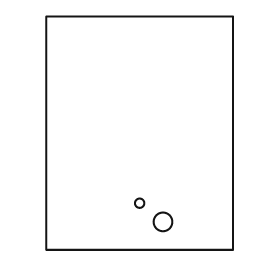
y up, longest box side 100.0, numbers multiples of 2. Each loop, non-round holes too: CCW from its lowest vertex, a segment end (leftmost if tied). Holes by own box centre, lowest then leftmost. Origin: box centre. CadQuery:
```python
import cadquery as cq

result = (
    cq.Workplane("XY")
    .moveTo(-40.0, -50.0)
    .lineTo(40.0, -50.0)
    .lineTo(40.0, 50.0)
    .lineTo(-40.0, 50.0)
    .close()
    .moveTo(10.0, -38.0)
    .circle(4.0)
    .moveTo(0.0, -30.0)
    .circle(2.0)
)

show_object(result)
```